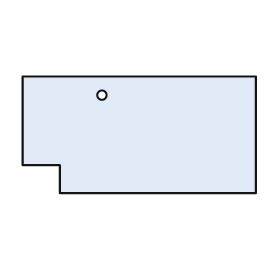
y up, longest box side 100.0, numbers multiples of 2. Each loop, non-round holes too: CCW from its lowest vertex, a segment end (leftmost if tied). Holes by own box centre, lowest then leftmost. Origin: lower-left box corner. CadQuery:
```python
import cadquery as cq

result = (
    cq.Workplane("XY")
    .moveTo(16.0, 0.0)
    .lineTo(100.0, 0.0)
    .lineTo(100.0, 50.0)
    .lineTo(0.0, 50.0)
    .lineTo(0.0, 12.0)
    .lineTo(16.0, 12.0)
    .close()
    .moveTo(34.0, 42.0)
    .circle(2.0)
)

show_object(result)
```